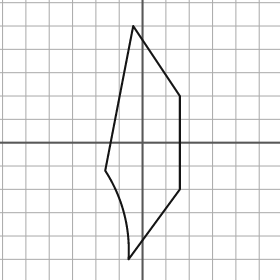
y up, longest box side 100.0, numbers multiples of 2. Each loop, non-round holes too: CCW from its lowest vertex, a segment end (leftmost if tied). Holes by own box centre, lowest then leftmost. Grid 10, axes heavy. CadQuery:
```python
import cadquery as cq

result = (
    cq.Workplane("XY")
    .moveTo(-6.0, -50.0)
    .lineTo(16.0, -20.0)
    .lineTo(16.0, 20.0)
    .lineTo(-4.0, 50.0)
    .lineTo(-16.0, -12.0)
    .threePointArc((-8.0, -30.0), (-6.0, -50.0))
    .close()
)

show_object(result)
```